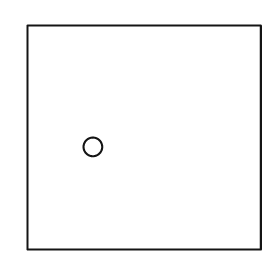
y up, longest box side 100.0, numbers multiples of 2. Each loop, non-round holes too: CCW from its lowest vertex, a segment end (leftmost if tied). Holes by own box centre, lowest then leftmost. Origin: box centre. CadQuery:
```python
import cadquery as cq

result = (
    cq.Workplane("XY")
    .moveTo(-50.0, -48.0)
    .lineTo(50.0, -48.0)
    .lineTo(50.0, 48.0)
    .lineTo(-50.0, 48.0)
    .close()
    .moveTo(-22.0, -4.0)
    .circle(4.0)
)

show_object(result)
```